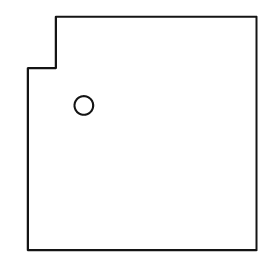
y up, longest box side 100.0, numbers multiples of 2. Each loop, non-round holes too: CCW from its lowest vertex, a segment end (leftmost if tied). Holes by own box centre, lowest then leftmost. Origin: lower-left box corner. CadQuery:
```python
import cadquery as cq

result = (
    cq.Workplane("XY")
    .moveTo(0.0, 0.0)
    .lineTo(98.0, 0.0)
    .lineTo(98.0, 100.0)
    .lineTo(12.0, 100.0)
    .lineTo(12.0, 78.0)
    .lineTo(0.0, 78.0)
    .close()
    .moveTo(24.0, 62.0)
    .circle(4.0)
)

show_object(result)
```